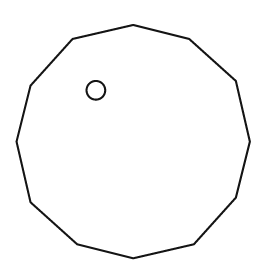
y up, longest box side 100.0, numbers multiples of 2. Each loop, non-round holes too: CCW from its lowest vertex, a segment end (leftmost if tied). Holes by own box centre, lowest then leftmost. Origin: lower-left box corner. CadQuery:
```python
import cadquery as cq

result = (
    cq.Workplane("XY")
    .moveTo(50.0, 0.0)
    .lineTo(76.0, 6.0)
    .lineTo(94.0, 26.0)
    .lineTo(100.0, 50.0)
    .lineTo(94.0, 76.0)
    .lineTo(74.0, 94.0)
    .lineTo(50.0, 100.0)
    .lineTo(24.0, 94.0)
    .lineTo(6.0, 74.0)
    .lineTo(0.0, 50.0)
    .lineTo(6.0, 24.0)
    .lineTo(26.0, 6.0)
    .close()
    .moveTo(34.0, 72.0)
    .circle(4.0)
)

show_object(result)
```